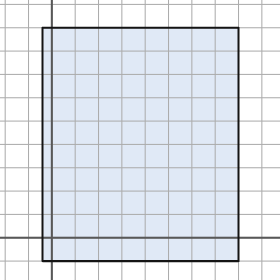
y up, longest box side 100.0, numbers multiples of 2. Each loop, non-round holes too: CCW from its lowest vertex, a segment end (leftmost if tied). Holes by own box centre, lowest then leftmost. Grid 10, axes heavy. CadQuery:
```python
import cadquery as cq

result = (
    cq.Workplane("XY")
    .moveTo(-4.0, -10.0)
    .lineTo(80.0, -10.0)
    .lineTo(80.0, 90.0)
    .lineTo(-4.0, 90.0)
    .close()
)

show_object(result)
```